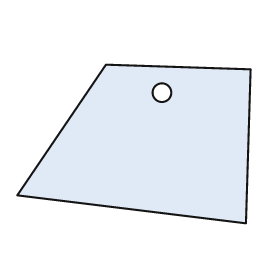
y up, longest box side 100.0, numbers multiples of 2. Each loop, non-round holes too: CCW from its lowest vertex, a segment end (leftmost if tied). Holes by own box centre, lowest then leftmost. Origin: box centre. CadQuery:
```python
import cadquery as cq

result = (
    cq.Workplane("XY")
    .moveTo(48.0, -34.0)
    .lineTo(50.0, 32.0)
    .lineTo(-12.0, 34.0)
    .lineTo(-50.0, -22.0)
    .close()
    .moveTo(12.0, 22.0)
    .circle(4.0)
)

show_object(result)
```